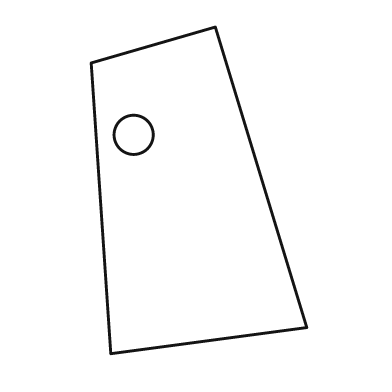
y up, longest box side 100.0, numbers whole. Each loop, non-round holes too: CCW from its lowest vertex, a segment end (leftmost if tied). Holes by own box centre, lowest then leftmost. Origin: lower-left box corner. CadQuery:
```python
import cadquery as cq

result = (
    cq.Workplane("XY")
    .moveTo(6.0, 0.0)
    .lineTo(66.0, 8.0)
    .lineTo(38.0, 100.0)
    .lineTo(0.0, 89.0)
    .close()
    .moveTo(13.0, 67.0)
    .circle(6.0)
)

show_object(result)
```